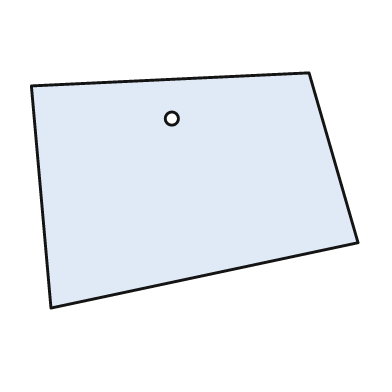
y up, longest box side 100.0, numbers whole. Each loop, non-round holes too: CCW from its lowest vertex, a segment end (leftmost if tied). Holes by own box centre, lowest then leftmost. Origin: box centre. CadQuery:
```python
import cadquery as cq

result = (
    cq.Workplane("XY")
    .moveTo(-44.0, -36.0)
    .lineTo(50.0, -16.0)
    .lineTo(35.0, 36.0)
    .lineTo(-50.0, 32.0)
    .close()
    .moveTo(-7.0, 22.0)
    .circle(2.0)
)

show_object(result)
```